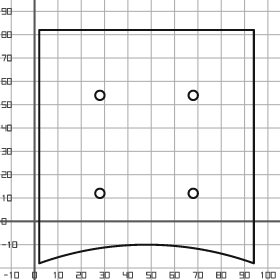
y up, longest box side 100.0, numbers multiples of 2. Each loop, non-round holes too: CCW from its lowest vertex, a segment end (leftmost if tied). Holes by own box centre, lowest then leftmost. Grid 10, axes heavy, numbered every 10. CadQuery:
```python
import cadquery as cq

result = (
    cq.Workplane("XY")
    .moveTo(2.0, -18.0)
    .threePointArc((48.0, -10.0), (94.0, -18.0))
    .lineTo(94.0, 82.0)
    .lineTo(2.0, 82.0)
    .close()
    .moveTo(28.0, 12.0)
    .circle(2.0)
    .moveTo(68.0, 12.0)
    .circle(2.0)
    .moveTo(28.0, 54.0)
    .circle(2.0)
    .moveTo(68.0, 54.0)
    .circle(2.0)
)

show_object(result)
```